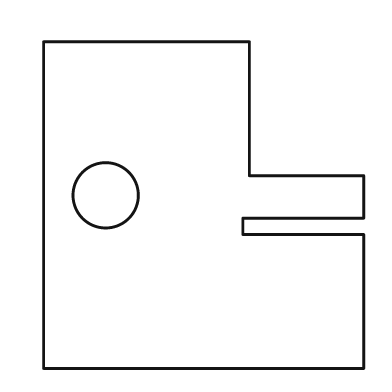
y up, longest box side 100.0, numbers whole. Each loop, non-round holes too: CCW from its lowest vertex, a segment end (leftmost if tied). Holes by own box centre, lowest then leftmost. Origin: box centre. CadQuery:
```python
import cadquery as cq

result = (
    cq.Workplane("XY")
    .moveTo(-49.0, -50.0)
    .lineTo(49.0, -50.0)
    .lineTo(49.0, -9.0)
    .lineTo(12.0, -9.0)
    .lineTo(12.0, -4.0)
    .lineTo(49.0, -4.0)
    .lineTo(49.0, 9.0)
    .lineTo(14.0, 9.0)
    .lineTo(14.0, 50.0)
    .lineTo(-49.0, 50.0)
    .close()
    .moveTo(-30.0, 3.0)
    .circle(10.0)
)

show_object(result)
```